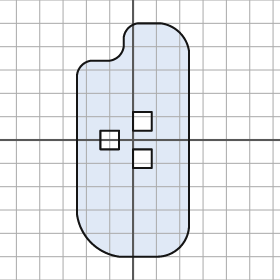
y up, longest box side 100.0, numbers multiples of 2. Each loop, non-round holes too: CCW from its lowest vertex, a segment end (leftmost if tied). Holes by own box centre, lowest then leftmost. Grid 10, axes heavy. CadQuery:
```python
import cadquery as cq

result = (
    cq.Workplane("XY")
    .moveTo(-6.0, -50.0)
    .lineTo(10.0, -50.0)
    .threePointArc((20.0, -46.0), (24.0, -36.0))
    .lineTo(24.0, 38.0)
    .threePointArc((20.0, 46.0), (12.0, 50.0))
    .lineTo(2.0, 50.0)
    .threePointArc((-2.0, 48.0), (-4.0, 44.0))
    .lineTo(-4.0, 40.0)
    .threePointArc((-6.0, 36.0), (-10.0, 34.0))
    .lineTo(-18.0, 34.0)
    .threePointArc((-22.0, 32.0), (-24.0, 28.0))
    .lineTo(-24.0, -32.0)
    .threePointArc((-18.0, -44.0), (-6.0, -50.0))
    .close()
    .moveTo(0.0, -12.0)
    .lineTo(8.0, -12.0)
    .lineTo(8.0, -4.0)
    .lineTo(0.0, -4.0)
    .close()
    .moveTo(-14.0, -4.0)
    .lineTo(-6.0, -4.0)
    .lineTo(-6.0, 4.0)
    .lineTo(-14.0, 4.0)
    .close()
    .moveTo(0.0, 4.0)
    .lineTo(8.0, 4.0)
    .lineTo(8.0, 12.0)
    .lineTo(0.0, 12.0)
    .close()
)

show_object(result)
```